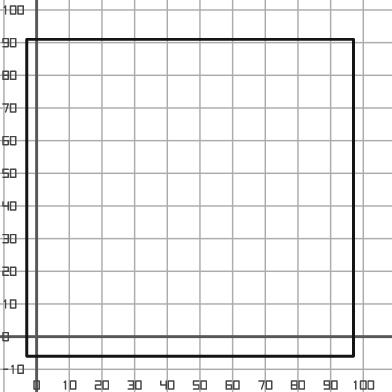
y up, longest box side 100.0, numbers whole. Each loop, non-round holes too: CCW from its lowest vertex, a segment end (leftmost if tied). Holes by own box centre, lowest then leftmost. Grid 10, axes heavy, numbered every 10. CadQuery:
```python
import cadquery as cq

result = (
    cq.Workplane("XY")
    .moveTo(-3.0, -6.0)
    .lineTo(97.0, -6.0)
    .lineTo(97.0, 91.0)
    .lineTo(-3.0, 91.0)
    .close()
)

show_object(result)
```